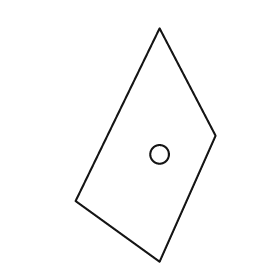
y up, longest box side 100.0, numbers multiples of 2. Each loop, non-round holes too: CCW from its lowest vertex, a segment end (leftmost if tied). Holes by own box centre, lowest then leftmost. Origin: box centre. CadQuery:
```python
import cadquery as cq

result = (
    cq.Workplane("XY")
    .moveTo(6.0, -50.0)
    .lineTo(30.0, 4.0)
    .lineTo(6.0, 50.0)
    .lineTo(-30.0, -24.0)
    .close()
    .moveTo(6.0, -4.0)
    .circle(4.0)
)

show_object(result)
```